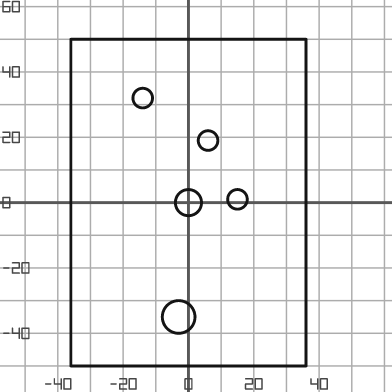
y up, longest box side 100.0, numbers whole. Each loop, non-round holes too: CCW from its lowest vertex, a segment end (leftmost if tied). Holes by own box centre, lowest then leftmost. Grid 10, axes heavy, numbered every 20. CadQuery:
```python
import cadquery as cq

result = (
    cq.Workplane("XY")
    .moveTo(-36.0, -50.0)
    .lineTo(36.0, -50.0)
    .lineTo(36.0, 50.0)
    .lineTo(-36.0, 50.0)
    .close()
    .moveTo(-3.0, -35.0)
    .circle(5.0)
    .moveTo(0.0, 0.0)
    .circle(4.0)
    .moveTo(15.0, 1.0)
    .circle(3.0)
    .moveTo(6.0, 19.0)
    .circle(3.0)
    .moveTo(-14.0, 32.0)
    .circle(3.0)
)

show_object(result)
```